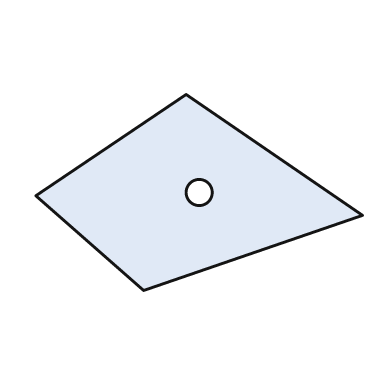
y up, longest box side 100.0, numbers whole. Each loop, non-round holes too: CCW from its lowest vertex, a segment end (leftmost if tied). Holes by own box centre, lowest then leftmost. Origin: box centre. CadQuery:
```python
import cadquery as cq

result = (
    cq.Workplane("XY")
    .moveTo(-17.0, -30.0)
    .lineTo(50.0, -7.0)
    .lineTo(-4.0, 30.0)
    .lineTo(-50.0, -1.0)
    .close()
    .moveTo(0.0, 0.0)
    .circle(4.0)
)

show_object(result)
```